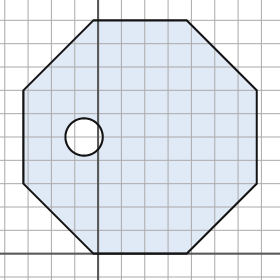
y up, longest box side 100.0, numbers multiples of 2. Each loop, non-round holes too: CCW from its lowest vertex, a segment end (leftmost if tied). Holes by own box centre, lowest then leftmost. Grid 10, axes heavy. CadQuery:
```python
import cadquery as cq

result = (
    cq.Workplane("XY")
    .moveTo(-2.0, 0.0)
    .lineTo(38.0, 0.0)
    .lineTo(68.0, 30.0)
    .lineTo(68.0, 70.0)
    .lineTo(38.0, 100.0)
    .lineTo(-2.0, 100.0)
    .lineTo(-32.0, 70.0)
    .lineTo(-32.0, 30.0)
    .close()
    .moveTo(-6.0, 50.0)
    .circle(8.0)
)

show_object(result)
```